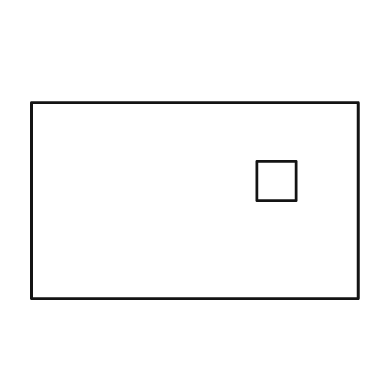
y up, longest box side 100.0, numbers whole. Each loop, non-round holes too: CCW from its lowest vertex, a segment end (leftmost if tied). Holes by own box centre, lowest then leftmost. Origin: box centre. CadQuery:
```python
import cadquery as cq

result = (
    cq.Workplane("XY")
    .moveTo(-50.0, -30.0)
    .lineTo(50.0, -30.0)
    .lineTo(50.0, 30.0)
    .lineTo(-50.0, 30.0)
    .close()
    .moveTo(19.0, 0.0)
    .lineTo(31.0, 0.0)
    .lineTo(31.0, 12.0)
    .lineTo(19.0, 12.0)
    .close()
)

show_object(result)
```